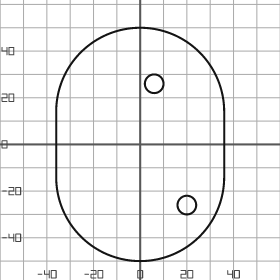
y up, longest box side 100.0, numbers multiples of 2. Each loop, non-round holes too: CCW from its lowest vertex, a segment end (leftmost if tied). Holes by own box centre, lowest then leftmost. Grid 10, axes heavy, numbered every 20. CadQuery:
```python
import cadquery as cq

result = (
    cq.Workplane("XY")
    .moveTo(-36.0, -14.0)
    .threePointArc((0.0, -50.0), (36.0, -14.0))
    .lineTo(36.0, 14.0)
    .threePointArc((0.0, 50.0), (-36.0, 14.0))
    .close()
    .moveTo(20.0, -26.0)
    .circle(4.0)
    .moveTo(6.0, 26.0)
    .circle(4.0)
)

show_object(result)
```